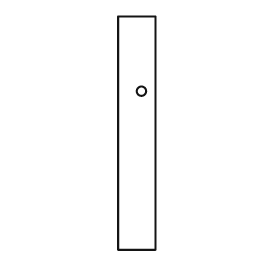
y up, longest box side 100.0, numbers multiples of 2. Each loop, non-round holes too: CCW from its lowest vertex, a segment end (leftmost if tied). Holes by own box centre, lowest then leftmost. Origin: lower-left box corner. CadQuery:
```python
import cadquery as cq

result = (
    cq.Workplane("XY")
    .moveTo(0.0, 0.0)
    .lineTo(16.0, 0.0)
    .lineTo(16.0, 100.0)
    .lineTo(0.0, 100.0)
    .close()
    .moveTo(10.0, 68.0)
    .circle(2.0)
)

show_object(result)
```